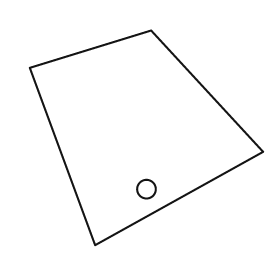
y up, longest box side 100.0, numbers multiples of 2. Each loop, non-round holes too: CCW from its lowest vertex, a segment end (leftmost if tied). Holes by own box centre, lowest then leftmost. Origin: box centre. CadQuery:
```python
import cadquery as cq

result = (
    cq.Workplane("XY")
    .moveTo(-22.0, -46.0)
    .lineTo(50.0, -6.0)
    .lineTo(2.0, 46.0)
    .lineTo(-50.0, 30.0)
    .close()
    .moveTo(0.0, -22.0)
    .circle(4.0)
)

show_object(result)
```